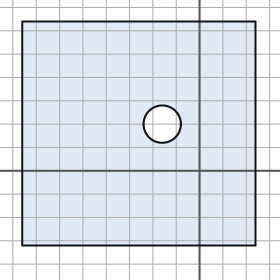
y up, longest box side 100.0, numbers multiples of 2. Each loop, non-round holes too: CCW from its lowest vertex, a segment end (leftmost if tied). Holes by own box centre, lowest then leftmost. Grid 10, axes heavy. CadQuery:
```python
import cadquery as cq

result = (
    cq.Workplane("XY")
    .moveTo(-76.0, -32.0)
    .lineTo(24.0, -32.0)
    .lineTo(24.0, 64.0)
    .lineTo(-76.0, 64.0)
    .close()
    .moveTo(-16.0, 20.0)
    .circle(8.0)
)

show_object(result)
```